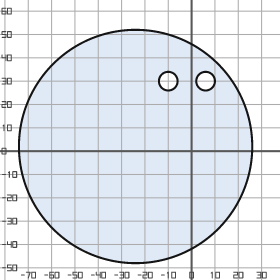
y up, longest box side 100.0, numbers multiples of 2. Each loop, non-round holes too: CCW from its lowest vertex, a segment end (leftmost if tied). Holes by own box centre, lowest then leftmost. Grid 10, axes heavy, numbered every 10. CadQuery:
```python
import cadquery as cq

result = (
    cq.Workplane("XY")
    .moveTo(-24.0, 2.0)
    .circle(50.0)
    .moveTo(-10.0, 30.0)
    .circle(4.0)
    .moveTo(6.0, 30.0)
    .circle(4.0)
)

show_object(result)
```